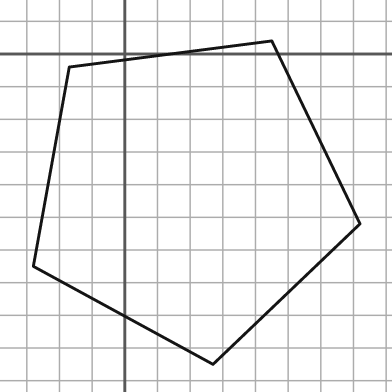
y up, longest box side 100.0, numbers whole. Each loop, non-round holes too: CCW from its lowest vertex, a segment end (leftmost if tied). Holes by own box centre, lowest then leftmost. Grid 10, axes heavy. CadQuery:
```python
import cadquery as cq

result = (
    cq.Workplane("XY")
    .moveTo(27.0, -95.0)
    .lineTo(72.0, -52.0)
    .lineTo(45.0, 4.0)
    .lineTo(-17.0, -4.0)
    .lineTo(-28.0, -65.0)
    .close()
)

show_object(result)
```